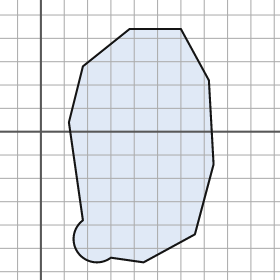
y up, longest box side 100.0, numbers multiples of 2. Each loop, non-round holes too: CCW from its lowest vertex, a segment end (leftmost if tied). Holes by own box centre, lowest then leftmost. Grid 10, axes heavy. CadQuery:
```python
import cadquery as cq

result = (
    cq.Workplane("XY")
    .moveTo(44.0, -56.0)
    .lineTo(66.0, -44.0)
    .lineTo(74.0, -14.0)
    .lineTo(72.0, 22.0)
    .lineTo(60.0, 44.0)
    .lineTo(38.0, 44.0)
    .lineTo(18.0, 28.0)
    .lineTo(12.0, 4.0)
    .lineTo(18.0, -38.0)
    .threePointArc((16.0, -52.0), (30.0, -54.0))
    .close()
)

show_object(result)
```